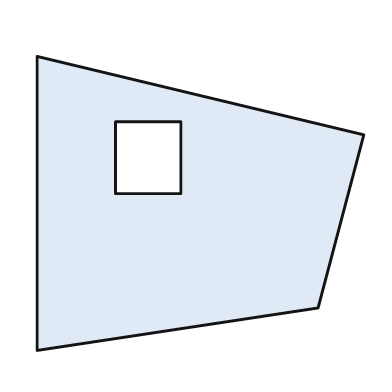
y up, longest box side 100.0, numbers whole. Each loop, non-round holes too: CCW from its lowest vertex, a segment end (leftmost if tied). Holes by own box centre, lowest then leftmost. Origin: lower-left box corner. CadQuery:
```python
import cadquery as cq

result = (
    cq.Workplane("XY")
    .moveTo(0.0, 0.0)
    .lineTo(86.0, 13.0)
    .lineTo(100.0, 66.0)
    .lineTo(0.0, 90.0)
    .close()
    .moveTo(24.0, 48.0)
    .lineTo(44.0, 48.0)
    .lineTo(44.0, 70.0)
    .lineTo(24.0, 70.0)
    .close()
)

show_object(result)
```